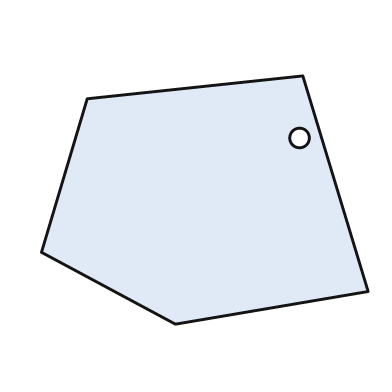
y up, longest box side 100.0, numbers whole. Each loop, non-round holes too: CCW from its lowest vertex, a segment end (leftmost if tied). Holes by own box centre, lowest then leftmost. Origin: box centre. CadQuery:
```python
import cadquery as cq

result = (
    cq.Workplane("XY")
    .moveTo(-9.0, -38.0)
    .lineTo(50.0, -28.0)
    .lineTo(30.0, 38.0)
    .lineTo(-36.0, 31.0)
    .lineTo(-50.0, -16.0)
    .close()
    .moveTo(29.0, 19.0)
    .circle(3.0)
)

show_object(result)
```